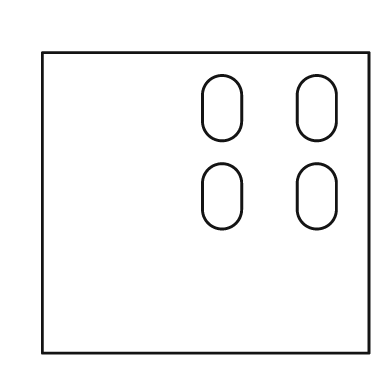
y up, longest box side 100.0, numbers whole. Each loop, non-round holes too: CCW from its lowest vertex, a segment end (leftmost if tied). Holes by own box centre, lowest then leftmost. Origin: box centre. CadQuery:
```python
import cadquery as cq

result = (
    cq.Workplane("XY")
    .moveTo(-50.0, -46.0)
    .lineTo(50.0, -46.0)
    .lineTo(50.0, 46.0)
    .lineTo(-50.0, 46.0)
    .close()
    .moveTo(-1.0, -2.0)
    .threePointArc((5.0, -8.0), (11.0, -2.0))
    .lineTo(11.0, 6.0)
    .threePointArc((5.0, 12.0), (-1.0, 6.0))
    .close()
    .moveTo(28.0, -2.0)
    .threePointArc((34.0, -8.0), (40.0, -2.0))
    .lineTo(40.0, 6.0)
    .threePointArc((34.0, 12.0), (28.0, 6.0))
    .close()
    .moveTo(-1.0, 25.0)
    .threePointArc((5.0, 19.0), (11.0, 25.0))
    .lineTo(11.0, 33.0)
    .threePointArc((5.0, 39.0), (-1.0, 33.0))
    .close()
    .moveTo(28.0, 25.0)
    .threePointArc((34.0, 19.0), (40.0, 25.0))
    .lineTo(40.0, 33.0)
    .threePointArc((34.0, 39.0), (28.0, 33.0))
    .close()
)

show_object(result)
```